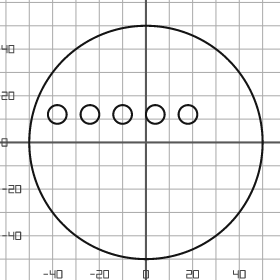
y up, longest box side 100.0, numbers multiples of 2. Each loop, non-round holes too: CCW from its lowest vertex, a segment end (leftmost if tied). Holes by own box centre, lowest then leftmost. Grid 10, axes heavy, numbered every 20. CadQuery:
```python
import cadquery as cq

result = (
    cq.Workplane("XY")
    .moveTo(0.0, 0.0)
    .circle(50.0)
    .moveTo(-38.0, 12.0)
    .circle(4.0)
    .moveTo(-24.0, 12.0)
    .circle(4.0)
    .moveTo(-10.0, 12.0)
    .circle(4.0)
    .moveTo(4.0, 12.0)
    .circle(4.0)
    .moveTo(18.0, 12.0)
    .circle(4.0)
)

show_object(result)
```